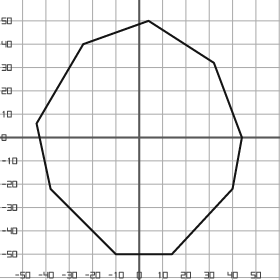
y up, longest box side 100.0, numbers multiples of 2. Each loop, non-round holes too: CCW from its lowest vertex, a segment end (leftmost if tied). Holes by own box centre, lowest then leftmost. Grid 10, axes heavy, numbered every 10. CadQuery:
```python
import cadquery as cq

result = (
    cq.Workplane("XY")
    .moveTo(-10.0, -50.0)
    .lineTo(14.0, -50.0)
    .lineTo(40.0, -22.0)
    .lineTo(44.0, 0.0)
    .lineTo(32.0, 32.0)
    .lineTo(4.0, 50.0)
    .lineTo(-24.0, 40.0)
    .lineTo(-44.0, 6.0)
    .lineTo(-38.0, -22.0)
    .close()
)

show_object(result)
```